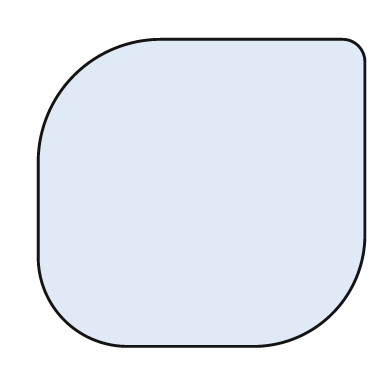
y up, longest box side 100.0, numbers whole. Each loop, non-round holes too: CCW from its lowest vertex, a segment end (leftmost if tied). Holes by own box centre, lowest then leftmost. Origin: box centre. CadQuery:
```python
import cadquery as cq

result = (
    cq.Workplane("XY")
    .moveTo(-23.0, -47.0)
    .lineTo(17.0, -47.0)
    .threePointArc((40.0, -37.0), (50.0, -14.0))
    .lineTo(50.0, 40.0)
    .threePointArc((48.0, 45.0), (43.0, 47.0))
    .lineTo(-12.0, 47.0)
    .threePointArc((-39.0, 36.0), (-50.0, 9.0))
    .lineTo(-50.0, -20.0)
    .threePointArc((-42.0, -39.0), (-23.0, -47.0))
    .close()
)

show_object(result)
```